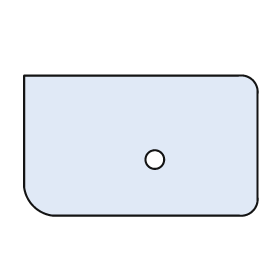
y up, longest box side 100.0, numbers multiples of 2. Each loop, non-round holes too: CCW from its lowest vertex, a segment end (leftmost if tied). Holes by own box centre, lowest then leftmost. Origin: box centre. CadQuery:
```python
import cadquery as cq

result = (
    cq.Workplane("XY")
    .moveTo(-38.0, -30.0)
    .lineTo(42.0, -30.0)
    .threePointArc((48.0, -28.0), (50.0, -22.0))
    .lineTo(50.0, 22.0)
    .threePointArc((48.0, 28.0), (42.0, 30.0))
    .lineTo(-50.0, 30.0)
    .lineTo(-50.0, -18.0)
    .threePointArc((-46.0, -26.0), (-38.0, -30.0))
    .close()
    .moveTo(6.0, -6.0)
    .circle(4.0)
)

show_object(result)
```